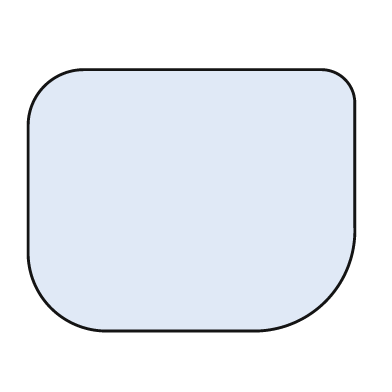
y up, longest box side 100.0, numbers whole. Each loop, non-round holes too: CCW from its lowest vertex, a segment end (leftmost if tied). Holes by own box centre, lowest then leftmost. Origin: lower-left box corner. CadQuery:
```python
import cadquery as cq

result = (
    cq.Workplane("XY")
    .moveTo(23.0, 0.0)
    .lineTo(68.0, 0.0)
    .threePointArc((91.0, 9.0), (100.0, 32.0))
    .lineTo(100.0, 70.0)
    .threePointArc((97.0, 77.0), (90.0, 80.0))
    .lineTo(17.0, 80.0)
    .threePointArc((5.0, 75.0), (0.0, 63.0))
    .lineTo(0.0, 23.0)
    .threePointArc((7.0, 7.0), (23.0, 0.0))
    .close()
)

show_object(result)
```